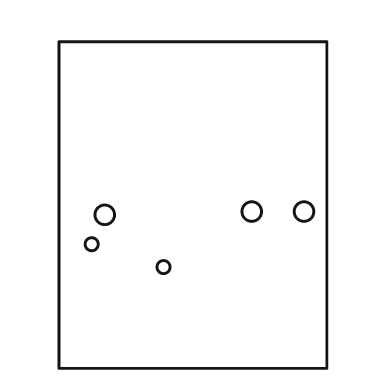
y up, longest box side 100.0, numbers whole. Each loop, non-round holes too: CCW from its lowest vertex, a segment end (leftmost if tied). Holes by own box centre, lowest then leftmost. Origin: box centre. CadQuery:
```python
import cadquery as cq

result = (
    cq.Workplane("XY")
    .moveTo(-41.0, -50.0)
    .lineTo(41.0, -50.0)
    .lineTo(41.0, 50.0)
    .lineTo(-41.0, 50.0)
    .close()
    .moveTo(-9.0, -19.0)
    .circle(2.0)
    .moveTo(-31.0, -12.0)
    .circle(2.0)
    .moveTo(-27.0, -3.0)
    .circle(3.0)
    .moveTo(18.0, -2.0)
    .circle(3.0)
    .moveTo(34.0, -2.0)
    .circle(3.0)
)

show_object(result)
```